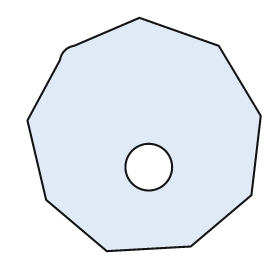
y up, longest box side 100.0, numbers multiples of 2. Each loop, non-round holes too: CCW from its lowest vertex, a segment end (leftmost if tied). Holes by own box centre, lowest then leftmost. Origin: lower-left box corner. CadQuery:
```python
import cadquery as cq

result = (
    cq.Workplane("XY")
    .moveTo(34.0, 0.0)
    .lineTo(70.0, 2.0)
    .lineTo(96.0, 24.0)
    .lineTo(100.0, 58.0)
    .lineTo(82.0, 88.0)
    .lineTo(48.0, 100.0)
    .lineTo(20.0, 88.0)
    .threePointArc((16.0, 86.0), (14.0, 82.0))
    .lineTo(0.0, 56.0)
    .lineTo(8.0, 22.0)
    .close()
    .moveTo(52.0, 36.0)
    .circle(10.0)
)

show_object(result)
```